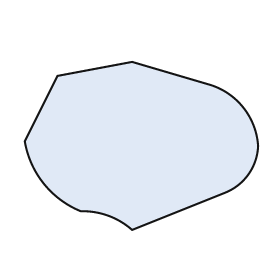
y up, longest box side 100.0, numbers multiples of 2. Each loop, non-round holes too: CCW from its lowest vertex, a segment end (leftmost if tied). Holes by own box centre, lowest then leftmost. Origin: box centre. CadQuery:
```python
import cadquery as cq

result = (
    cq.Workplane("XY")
    .moveTo(-4.0, -36.0)
    .lineTo(36.0, -20.0)
    .threePointArc((46.0, -12.0), (50.0, 0.0))
    .threePointArc((44.0, 16.0), (30.0, 26.0))
    .lineTo(-4.0, 36.0)
    .lineTo(-36.0, 30.0)
    .lineTo(-50.0, 2.0)
    .threePointArc((-42.0, -16.0), (-26.0, -28.0))
    .threePointArc((-14.0, -30.0), (-4.0, -36.0))
    .close()
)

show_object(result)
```